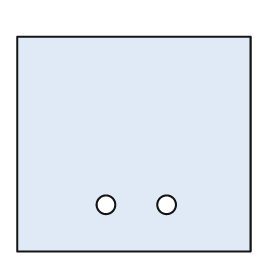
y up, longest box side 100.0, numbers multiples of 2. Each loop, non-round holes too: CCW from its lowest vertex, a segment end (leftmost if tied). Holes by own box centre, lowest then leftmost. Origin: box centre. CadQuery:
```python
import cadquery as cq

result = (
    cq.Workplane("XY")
    .moveTo(-50.0, -46.0)
    .lineTo(50.0, -46.0)
    .lineTo(50.0, 46.0)
    .lineTo(-50.0, 46.0)
    .close()
    .moveTo(-12.0, -26.0)
    .circle(4.0)
    .moveTo(14.0, -26.0)
    .circle(4.0)
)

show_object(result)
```